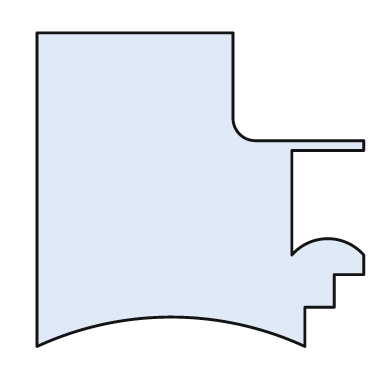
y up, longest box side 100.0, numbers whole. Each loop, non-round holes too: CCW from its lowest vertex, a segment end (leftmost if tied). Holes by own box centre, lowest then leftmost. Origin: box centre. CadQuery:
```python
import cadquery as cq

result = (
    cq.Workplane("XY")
    .moveTo(-50.0, -48.0)
    .threePointArc((-9.0, -39.0), (32.0, -48.0))
    .lineTo(32.0, -36.0)
    .lineTo(41.0, -36.0)
    .lineTo(41.0, -26.0)
    .lineTo(50.0, -26.0)
    .lineTo(50.0, -20.0)
    .threePointArc((39.0, -15.0), (28.0, -20.0))
    .lineTo(28.0, 12.0)
    .lineTo(50.0, 12.0)
    .lineTo(50.0, 15.0)
    .lineTo(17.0, 15.0)
    .threePointArc((12.0, 17.0), (10.0, 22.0))
    .lineTo(10.0, 48.0)
    .lineTo(-50.0, 48.0)
    .close()
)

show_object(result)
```